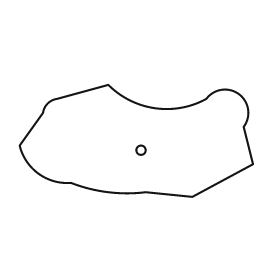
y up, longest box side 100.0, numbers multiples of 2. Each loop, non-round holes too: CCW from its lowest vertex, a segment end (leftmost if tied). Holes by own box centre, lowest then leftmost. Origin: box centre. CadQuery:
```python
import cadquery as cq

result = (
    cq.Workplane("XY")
    .moveTo(24.0, -24.0)
    .lineTo(50.0, -10.0)
    .lineTo(46.0, 6.0)
    .threePointArc((44.0, 20.0), (30.0, 18.0))
    .threePointArc((8.0, 14.0), (-12.0, 24.0))
    .lineTo(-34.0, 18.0)
    .threePointArc((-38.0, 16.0), (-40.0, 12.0))
    .lineTo(-50.0, -2.0)
    .threePointArc((-42.0, -14.0), (-28.0, -18.0))
    .threePointArc((-12.0, -22.0), (4.0, -22.0))
    .close()
    .moveTo(2.0, -4.0)
    .circle(2.0)
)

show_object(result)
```